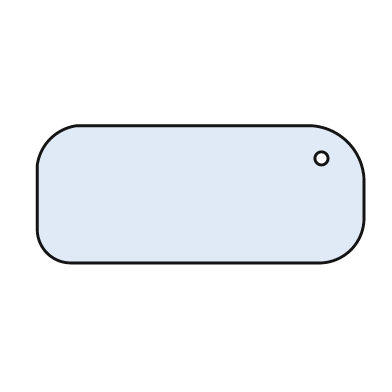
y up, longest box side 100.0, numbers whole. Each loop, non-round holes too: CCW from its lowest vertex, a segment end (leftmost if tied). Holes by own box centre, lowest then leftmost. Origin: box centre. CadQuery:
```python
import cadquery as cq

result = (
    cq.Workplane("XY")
    .moveTo(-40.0, -21.0)
    .lineTo(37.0, -21.0)
    .threePointArc((46.0, -17.0), (50.0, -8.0))
    .lineTo(50.0, 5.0)
    .threePointArc((45.0, 16.0), (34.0, 21.0))
    .lineTo(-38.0, 21.0)
    .threePointArc((-46.0, 17.0), (-50.0, 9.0))
    .lineTo(-50.0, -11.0)
    .threePointArc((-47.0, -18.0), (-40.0, -21.0))
    .close()
    .moveTo(37.0, 11.0)
    .circle(2.0)
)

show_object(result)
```